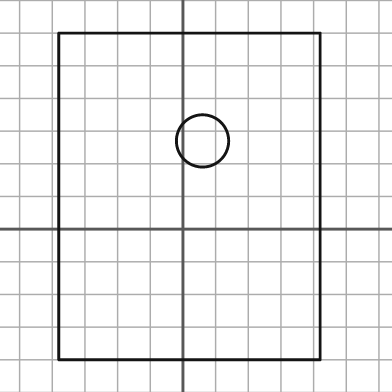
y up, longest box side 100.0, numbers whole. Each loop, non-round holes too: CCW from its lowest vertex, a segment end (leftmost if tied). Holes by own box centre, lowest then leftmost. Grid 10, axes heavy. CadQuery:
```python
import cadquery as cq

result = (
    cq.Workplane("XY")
    .moveTo(-38.0, -40.0)
    .lineTo(42.0, -40.0)
    .lineTo(42.0, 60.0)
    .lineTo(-38.0, 60.0)
    .close()
    .moveTo(6.0, 27.0)
    .circle(8.0)
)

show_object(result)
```